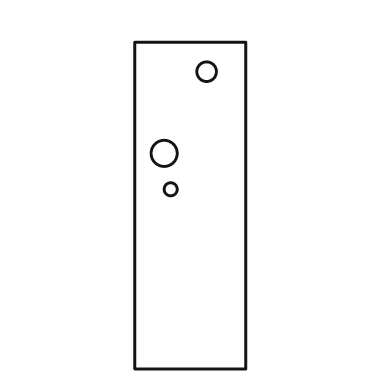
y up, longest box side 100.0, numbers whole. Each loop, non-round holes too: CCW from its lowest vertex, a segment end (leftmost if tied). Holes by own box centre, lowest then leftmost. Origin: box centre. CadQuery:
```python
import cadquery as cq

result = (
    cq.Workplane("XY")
    .moveTo(-17.0, -50.0)
    .lineTo(17.0, -50.0)
    .lineTo(17.0, 50.0)
    .lineTo(-17.0, 50.0)
    .close()
    .moveTo(-6.0, 5.0)
    .circle(2.0)
    .moveTo(-8.0, 16.0)
    .circle(4.0)
    .moveTo(5.0, 41.0)
    .circle(3.0)
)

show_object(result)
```